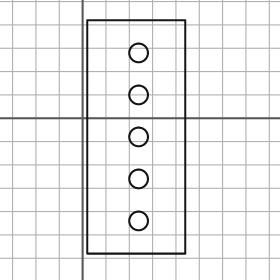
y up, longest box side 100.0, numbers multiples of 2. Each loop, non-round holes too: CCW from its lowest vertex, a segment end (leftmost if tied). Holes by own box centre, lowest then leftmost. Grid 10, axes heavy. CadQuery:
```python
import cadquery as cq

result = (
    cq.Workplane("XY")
    .moveTo(2.0, -58.0)
    .lineTo(44.0, -58.0)
    .lineTo(44.0, 42.0)
    .lineTo(2.0, 42.0)
    .close()
    .moveTo(24.0, -44.0)
    .circle(4.0)
    .moveTo(24.0, -26.0)
    .circle(4.0)
    .moveTo(24.0, -8.0)
    .circle(4.0)
    .moveTo(24.0, 10.0)
    .circle(4.0)
    .moveTo(24.0, 28.0)
    .circle(4.0)
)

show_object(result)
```